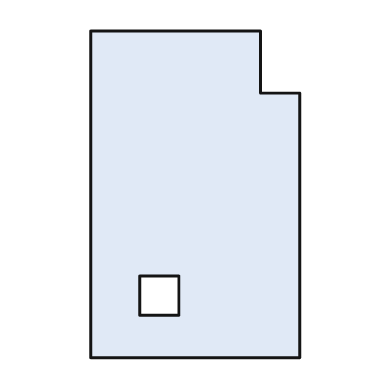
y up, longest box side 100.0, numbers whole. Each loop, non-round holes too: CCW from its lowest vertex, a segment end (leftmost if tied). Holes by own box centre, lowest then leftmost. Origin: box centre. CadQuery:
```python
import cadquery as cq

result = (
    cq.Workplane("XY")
    .moveTo(-32.0, -50.0)
    .lineTo(32.0, -50.0)
    .lineTo(32.0, 31.0)
    .lineTo(20.0, 31.0)
    .lineTo(20.0, 50.0)
    .lineTo(-32.0, 50.0)
    .close()
    .moveTo(-17.0, -37.0)
    .lineTo(-5.0, -37.0)
    .lineTo(-5.0, -25.0)
    .lineTo(-17.0, -25.0)
    .close()
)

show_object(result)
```